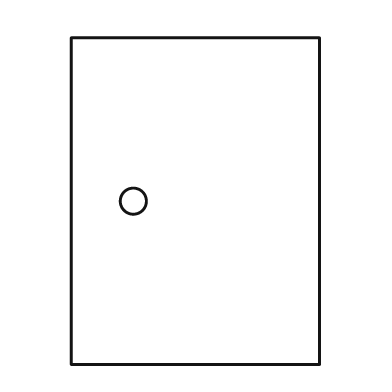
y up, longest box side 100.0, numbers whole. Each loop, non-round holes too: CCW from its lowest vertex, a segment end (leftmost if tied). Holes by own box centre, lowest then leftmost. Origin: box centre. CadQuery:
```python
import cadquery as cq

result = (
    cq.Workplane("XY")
    .moveTo(-38.0, -50.0)
    .lineTo(38.0, -50.0)
    .lineTo(38.0, 50.0)
    .lineTo(-38.0, 50.0)
    .close()
    .moveTo(-19.0, 0.0)
    .circle(4.0)
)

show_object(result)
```